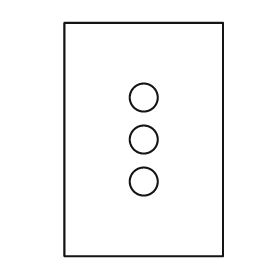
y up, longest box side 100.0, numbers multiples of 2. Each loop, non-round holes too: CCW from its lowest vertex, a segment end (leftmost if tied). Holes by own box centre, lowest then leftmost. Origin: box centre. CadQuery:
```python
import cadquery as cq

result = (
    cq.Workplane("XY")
    .moveTo(-34.0, -50.0)
    .lineTo(34.0, -50.0)
    .lineTo(34.0, 50.0)
    .lineTo(-34.0, 50.0)
    .close()
    .moveTo(0.0, -18.0)
    .circle(6.0)
    .moveTo(0.0, 0.0)
    .circle(6.0)
    .moveTo(0.0, 18.0)
    .circle(6.0)
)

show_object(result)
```